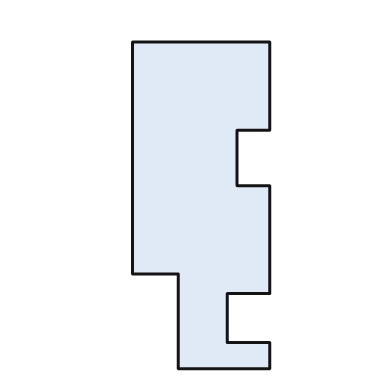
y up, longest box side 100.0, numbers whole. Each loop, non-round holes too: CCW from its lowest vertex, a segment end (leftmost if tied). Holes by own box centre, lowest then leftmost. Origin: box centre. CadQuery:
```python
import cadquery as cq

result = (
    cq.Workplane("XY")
    .moveTo(-7.0, -50.0)
    .lineTo(21.0, -50.0)
    .lineTo(21.0, -42.0)
    .lineTo(8.0, -42.0)
    .lineTo(8.0, -27.0)
    .lineTo(21.0, -27.0)
    .lineTo(21.0, 6.0)
    .lineTo(11.0, 6.0)
    .lineTo(11.0, 23.0)
    .lineTo(21.0, 23.0)
    .lineTo(21.0, 50.0)
    .lineTo(-21.0, 50.0)
    .lineTo(-21.0, -21.0)
    .lineTo(-7.0, -21.0)
    .close()
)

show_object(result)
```